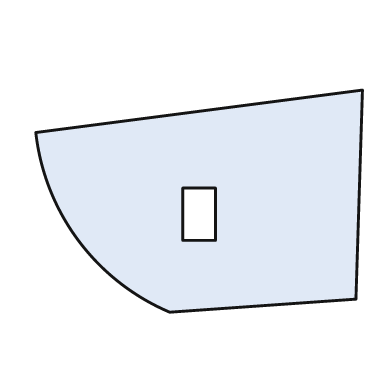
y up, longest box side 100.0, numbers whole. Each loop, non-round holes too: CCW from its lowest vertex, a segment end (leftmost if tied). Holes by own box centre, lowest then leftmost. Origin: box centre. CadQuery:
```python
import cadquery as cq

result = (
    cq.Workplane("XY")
    .moveTo(-9.0, -34.0)
    .lineTo(48.0, -30.0)
    .lineTo(50.0, 34.0)
    .lineTo(-50.0, 21.0)
    .threePointArc((-37.0, -12.0), (-9.0, -34.0))
    .close()
    .moveTo(-5.0, -12.0)
    .lineTo(5.0, -12.0)
    .lineTo(5.0, 4.0)
    .lineTo(-5.0, 4.0)
    .close()
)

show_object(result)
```